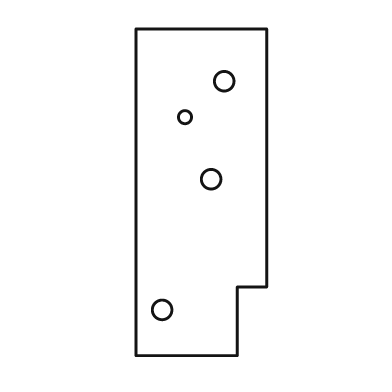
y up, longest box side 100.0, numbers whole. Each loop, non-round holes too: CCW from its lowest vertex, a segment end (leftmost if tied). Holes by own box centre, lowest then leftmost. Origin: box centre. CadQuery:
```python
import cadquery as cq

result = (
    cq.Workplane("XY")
    .moveTo(-20.0, -50.0)
    .lineTo(11.0, -50.0)
    .lineTo(11.0, -29.0)
    .lineTo(20.0, -29.0)
    .lineTo(20.0, 50.0)
    .lineTo(-20.0, 50.0)
    .close()
    .moveTo(-12.0, -36.0)
    .circle(3.0)
    .moveTo(3.0, 4.0)
    .circle(3.0)
    .moveTo(-5.0, 23.0)
    .circle(2.0)
    .moveTo(7.0, 34.0)
    .circle(3.0)
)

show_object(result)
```